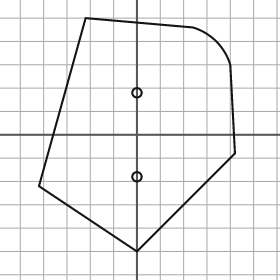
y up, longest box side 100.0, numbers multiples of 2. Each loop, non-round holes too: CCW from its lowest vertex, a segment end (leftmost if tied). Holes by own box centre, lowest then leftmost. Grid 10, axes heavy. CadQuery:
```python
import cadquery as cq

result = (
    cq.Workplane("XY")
    .moveTo(0.0, -50.0)
    .lineTo(42.0, -8.0)
    .lineTo(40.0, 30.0)
    .threePointArc((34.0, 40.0), (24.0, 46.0))
    .lineTo(-22.0, 50.0)
    .lineTo(-42.0, -22.0)
    .close()
    .moveTo(0.0, -18.0)
    .circle(2.0)
    .moveTo(0.0, 18.0)
    .circle(2.0)
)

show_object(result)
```